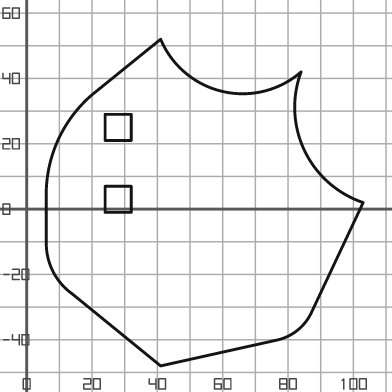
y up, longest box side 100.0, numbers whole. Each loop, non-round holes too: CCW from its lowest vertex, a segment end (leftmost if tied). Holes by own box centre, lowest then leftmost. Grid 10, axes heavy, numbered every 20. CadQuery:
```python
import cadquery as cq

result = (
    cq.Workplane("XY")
    .moveTo(41.0, -48.0)
    .lineTo(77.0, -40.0)
    .threePointArc((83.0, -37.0), (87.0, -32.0))
    .lineTo(103.0, 2.0)
    .threePointArc((85.0, 18.0), (84.0, 42.0))
    .threePointArc((60.0, 36.0), (41.0, 52.0))
    .lineTo(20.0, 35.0)
    .threePointArc((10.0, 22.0), (6.0, 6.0))
    .lineTo(6.0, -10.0)
    .threePointArc((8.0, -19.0), (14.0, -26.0))
    .close()
    .moveTo(24.0, -1.0)
    .lineTo(32.0, -1.0)
    .lineTo(32.0, 7.0)
    .lineTo(24.0, 7.0)
    .close()
    .moveTo(24.0, 21.0)
    .lineTo(32.0, 21.0)
    .lineTo(32.0, 29.0)
    .lineTo(24.0, 29.0)
    .close()
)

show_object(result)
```